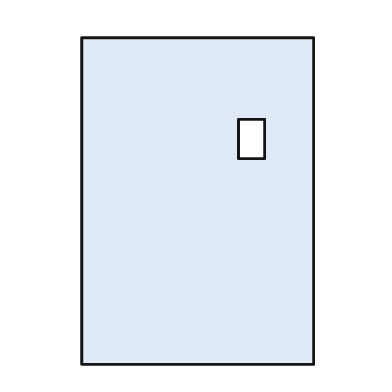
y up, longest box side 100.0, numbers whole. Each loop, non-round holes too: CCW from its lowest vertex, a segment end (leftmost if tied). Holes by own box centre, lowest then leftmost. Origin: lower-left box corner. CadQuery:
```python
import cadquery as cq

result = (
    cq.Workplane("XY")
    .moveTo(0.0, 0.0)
    .lineTo(71.0, 0.0)
    .lineTo(71.0, 100.0)
    .lineTo(0.0, 100.0)
    .close()
    .moveTo(48.0, 63.0)
    .lineTo(56.0, 63.0)
    .lineTo(56.0, 75.0)
    .lineTo(48.0, 75.0)
    .close()
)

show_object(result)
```